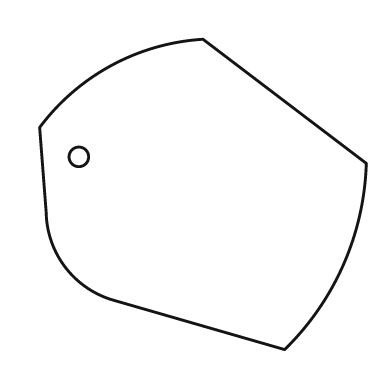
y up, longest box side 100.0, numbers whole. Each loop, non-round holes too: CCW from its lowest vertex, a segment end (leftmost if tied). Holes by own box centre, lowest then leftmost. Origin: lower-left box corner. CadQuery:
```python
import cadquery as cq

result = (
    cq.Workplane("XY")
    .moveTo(75.0, 0.0)
    .threePointArc((93.0, 26.0), (100.0, 57.0))
    .lineTo(50.0, 95.0)
    .threePointArc((22.0, 87.0), (0.0, 68.0))
    .lineTo(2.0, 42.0)
    .threePointArc((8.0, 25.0), (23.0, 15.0))
    .close()
    .moveTo(12.0, 59.0)
    .circle(3.0)
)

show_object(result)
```